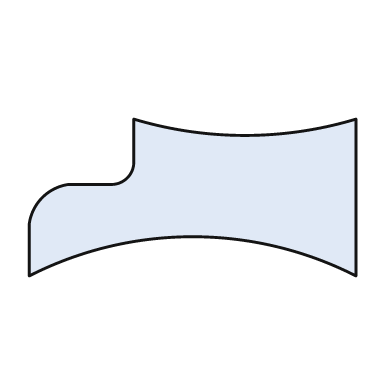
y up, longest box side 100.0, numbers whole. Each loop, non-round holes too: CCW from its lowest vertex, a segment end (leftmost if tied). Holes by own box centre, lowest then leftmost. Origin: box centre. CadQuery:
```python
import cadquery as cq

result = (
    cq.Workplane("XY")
    .moveTo(-50.0, -24.0)
    .threePointArc((0.0, -12.0), (50.0, -24.0))
    .lineTo(50.0, 24.0)
    .threePointArc((16.0, 19.0), (-18.0, 24.0))
    .lineTo(-18.0, 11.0)
    .threePointArc((-20.0, 6.0), (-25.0, 4.0))
    .lineTo(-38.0, 4.0)
    .threePointArc((-46.0, 0.0), (-50.0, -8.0))
    .close()
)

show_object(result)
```